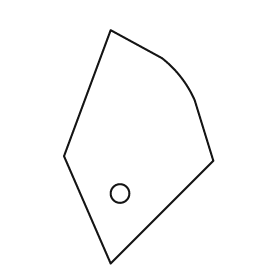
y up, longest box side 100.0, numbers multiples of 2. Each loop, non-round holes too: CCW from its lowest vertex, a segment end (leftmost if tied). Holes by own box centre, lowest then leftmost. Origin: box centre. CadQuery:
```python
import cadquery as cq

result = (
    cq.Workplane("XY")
    .moveTo(-12.0, -50.0)
    .lineTo(32.0, -6.0)
    .lineTo(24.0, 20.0)
    .threePointArc((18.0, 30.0), (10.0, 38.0))
    .lineTo(-12.0, 50.0)
    .lineTo(-32.0, -4.0)
    .close()
    .moveTo(-8.0, -20.0)
    .circle(4.0)
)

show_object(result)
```